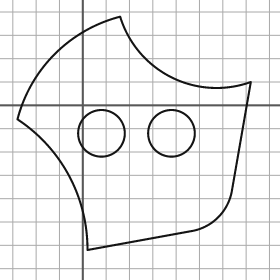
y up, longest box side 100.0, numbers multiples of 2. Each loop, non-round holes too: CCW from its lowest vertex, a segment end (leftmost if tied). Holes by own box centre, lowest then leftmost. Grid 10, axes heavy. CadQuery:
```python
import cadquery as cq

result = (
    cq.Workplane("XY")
    .moveTo(2.0, -62.0)
    .lineTo(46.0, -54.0)
    .threePointArc((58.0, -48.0), (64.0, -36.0))
    .lineTo(72.0, 10.0)
    .threePointArc((38.0, 12.0), (16.0, 38.0))
    .threePointArc((-12.0, 22.0), (-28.0, -6.0))
    .threePointArc((-6.0, -30.0), (2.0, -62.0))
    .close()
    .moveTo(8.0, -12.0)
    .circle(10.0)
    .moveTo(38.0, -12.0)
    .circle(10.0)
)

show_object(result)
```